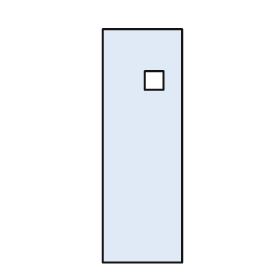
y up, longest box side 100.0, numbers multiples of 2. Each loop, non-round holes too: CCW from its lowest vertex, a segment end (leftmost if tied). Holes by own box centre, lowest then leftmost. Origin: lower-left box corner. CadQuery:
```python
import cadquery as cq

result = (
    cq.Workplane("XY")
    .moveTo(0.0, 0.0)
    .lineTo(34.0, 0.0)
    .lineTo(34.0, 100.0)
    .lineTo(0.0, 100.0)
    .close()
    .moveTo(18.0, 74.0)
    .lineTo(26.0, 74.0)
    .lineTo(26.0, 82.0)
    .lineTo(18.0, 82.0)
    .close()
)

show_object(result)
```